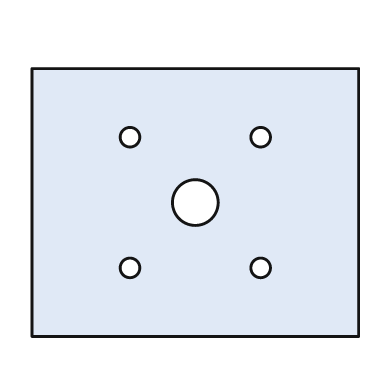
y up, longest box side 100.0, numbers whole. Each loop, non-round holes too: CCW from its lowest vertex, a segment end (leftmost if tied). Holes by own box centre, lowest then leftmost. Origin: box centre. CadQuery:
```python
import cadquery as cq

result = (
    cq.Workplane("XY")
    .moveTo(-50.0, -41.0)
    .lineTo(50.0, -41.0)
    .lineTo(50.0, 41.0)
    .lineTo(-50.0, 41.0)
    .close()
    .moveTo(-20.0, -20.0)
    .circle(3.0)
    .moveTo(20.0, -20.0)
    .circle(3.0)
    .moveTo(0.0, 0.0)
    .circle(7.0)
    .moveTo(-20.0, 20.0)
    .circle(3.0)
    .moveTo(20.0, 20.0)
    .circle(3.0)
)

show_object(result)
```